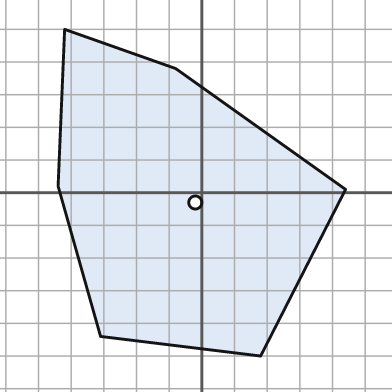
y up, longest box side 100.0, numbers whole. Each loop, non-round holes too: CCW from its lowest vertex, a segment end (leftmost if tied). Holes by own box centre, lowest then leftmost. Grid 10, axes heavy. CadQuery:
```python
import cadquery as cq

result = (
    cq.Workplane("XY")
    .moveTo(18.0, -50.0)
    .lineTo(44.0, 1.0)
    .lineTo(-8.0, 38.0)
    .lineTo(-42.0, 50.0)
    .lineTo(-44.0, 2.0)
    .lineTo(-31.0, -44.0)
    .close()
    .moveTo(-2.0, -3.0)
    .circle(2.0)
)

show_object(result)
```